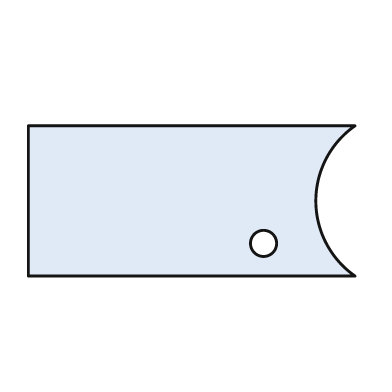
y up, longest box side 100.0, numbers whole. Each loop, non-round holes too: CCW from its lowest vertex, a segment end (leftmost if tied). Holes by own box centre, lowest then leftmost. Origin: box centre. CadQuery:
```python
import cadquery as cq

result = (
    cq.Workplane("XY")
    .moveTo(-50.0, -23.0)
    .lineTo(50.0, -23.0)
    .threePointArc((38.0, 0.0), (50.0, 23.0))
    .lineTo(-50.0, 23.0)
    .close()
    .moveTo(22.0, -13.0)
    .circle(4.0)
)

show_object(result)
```